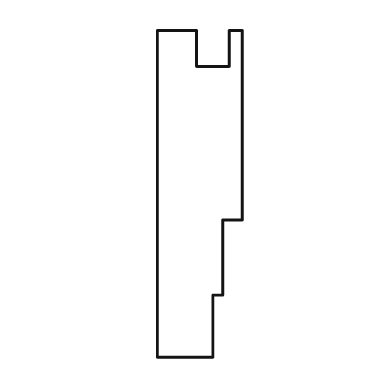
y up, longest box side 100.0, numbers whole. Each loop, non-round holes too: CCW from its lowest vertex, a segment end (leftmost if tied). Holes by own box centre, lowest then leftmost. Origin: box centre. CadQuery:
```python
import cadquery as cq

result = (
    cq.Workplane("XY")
    .moveTo(-13.0, -50.0)
    .lineTo(4.0, -50.0)
    .lineTo(4.0, -31.0)
    .lineTo(7.0, -31.0)
    .lineTo(7.0, -8.0)
    .lineTo(13.0, -8.0)
    .lineTo(13.0, 50.0)
    .lineTo(9.0, 50.0)
    .lineTo(9.0, 39.0)
    .lineTo(-1.0, 39.0)
    .lineTo(-1.0, 50.0)
    .lineTo(-13.0, 50.0)
    .close()
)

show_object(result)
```